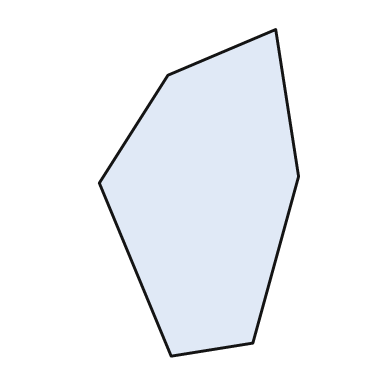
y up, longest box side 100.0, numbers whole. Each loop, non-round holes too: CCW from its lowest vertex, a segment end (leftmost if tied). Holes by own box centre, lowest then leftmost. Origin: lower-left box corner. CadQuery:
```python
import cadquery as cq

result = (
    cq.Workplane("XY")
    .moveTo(22.0, 0.0)
    .lineTo(47.0, 4.0)
    .lineTo(61.0, 55.0)
    .lineTo(54.0, 100.0)
    .lineTo(21.0, 86.0)
    .lineTo(0.0, 53.0)
    .close()
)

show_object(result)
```